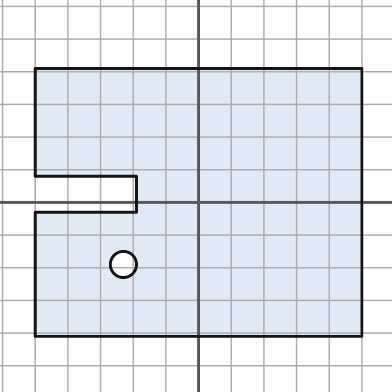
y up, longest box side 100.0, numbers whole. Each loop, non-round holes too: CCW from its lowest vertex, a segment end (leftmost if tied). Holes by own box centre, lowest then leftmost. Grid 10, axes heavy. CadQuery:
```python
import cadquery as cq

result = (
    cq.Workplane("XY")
    .moveTo(-50.0, -41.0)
    .lineTo(50.0, -41.0)
    .lineTo(50.0, 41.0)
    .lineTo(-50.0, 41.0)
    .lineTo(-50.0, 8.0)
    .lineTo(-19.0, 8.0)
    .lineTo(-19.0, -3.0)
    .lineTo(-50.0, -3.0)
    .close()
    .moveTo(-23.0, -19.0)
    .circle(4.0)
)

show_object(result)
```